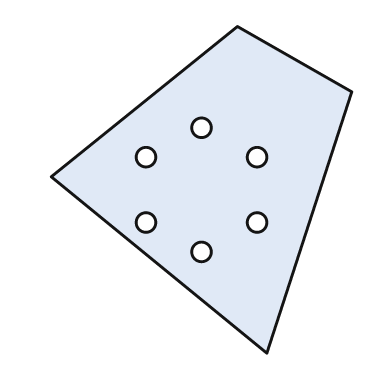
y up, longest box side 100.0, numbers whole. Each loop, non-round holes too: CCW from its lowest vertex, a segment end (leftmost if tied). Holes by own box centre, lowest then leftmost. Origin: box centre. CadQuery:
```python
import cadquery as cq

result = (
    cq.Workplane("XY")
    .moveTo(20.0, -50.0)
    .lineTo(46.0, 30.0)
    .lineTo(11.0, 50.0)
    .lineTo(-46.0, 4.0)
    .close()
    .moveTo(0.0, -19.0)
    .circle(3.0)
    .moveTo(-17.0, -10.0)
    .circle(3.0)
    .moveTo(17.0, -10.0)
    .circle(3.0)
    .moveTo(-17.0, 10.0)
    .circle(3.0)
    .moveTo(17.0, 10.0)
    .circle(3.0)
    .moveTo(0.0, 19.0)
    .circle(3.0)
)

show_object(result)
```